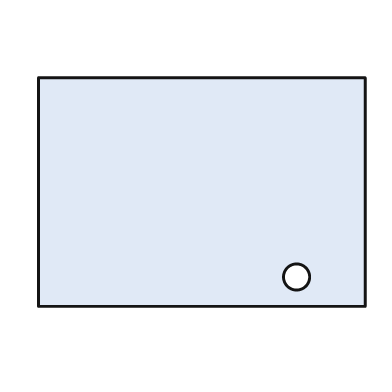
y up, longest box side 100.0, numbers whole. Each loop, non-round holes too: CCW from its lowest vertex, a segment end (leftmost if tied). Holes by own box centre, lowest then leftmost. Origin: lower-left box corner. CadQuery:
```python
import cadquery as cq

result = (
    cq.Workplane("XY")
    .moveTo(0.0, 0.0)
    .lineTo(100.0, 0.0)
    .lineTo(100.0, 70.0)
    .lineTo(0.0, 70.0)
    .close()
    .moveTo(79.0, 9.0)
    .circle(4.0)
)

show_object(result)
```